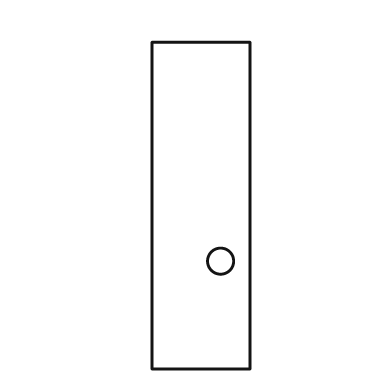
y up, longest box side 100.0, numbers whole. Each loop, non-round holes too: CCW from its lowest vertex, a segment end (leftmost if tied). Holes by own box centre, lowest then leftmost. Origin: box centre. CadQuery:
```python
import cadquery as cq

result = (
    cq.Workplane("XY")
    .moveTo(-15.0, -50.0)
    .lineTo(15.0, -50.0)
    .lineTo(15.0, 50.0)
    .lineTo(-15.0, 50.0)
    .close()
    .moveTo(6.0, -17.0)
    .circle(4.0)
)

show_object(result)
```